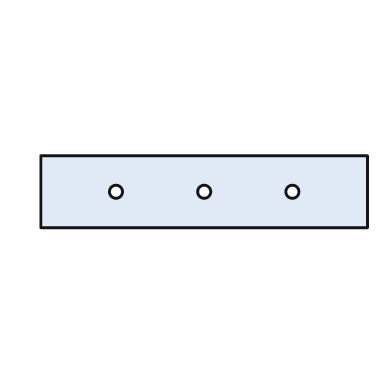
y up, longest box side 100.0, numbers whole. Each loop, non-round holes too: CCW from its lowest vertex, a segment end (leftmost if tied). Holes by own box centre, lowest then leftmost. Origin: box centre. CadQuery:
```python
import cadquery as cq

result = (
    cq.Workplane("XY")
    .moveTo(-50.0, -11.0)
    .lineTo(50.0, -11.0)
    .lineTo(50.0, 11.0)
    .lineTo(-50.0, 11.0)
    .close()
    .moveTo(-27.0, 0.0)
    .circle(2.0)
    .moveTo(0.0, 0.0)
    .circle(2.0)
    .moveTo(27.0, 0.0)
    .circle(2.0)
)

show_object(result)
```